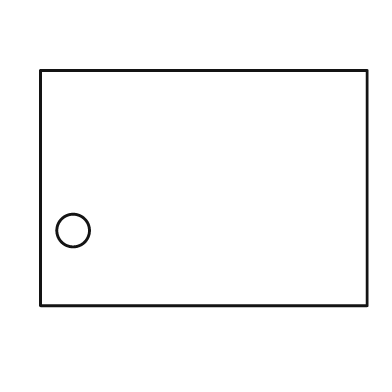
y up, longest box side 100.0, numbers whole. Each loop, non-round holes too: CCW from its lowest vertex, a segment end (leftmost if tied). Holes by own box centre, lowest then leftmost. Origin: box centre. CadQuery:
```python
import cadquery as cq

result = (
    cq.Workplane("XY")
    .moveTo(-50.0, -36.0)
    .lineTo(50.0, -36.0)
    .lineTo(50.0, 36.0)
    .lineTo(-50.0, 36.0)
    .close()
    .moveTo(-40.0, -13.0)
    .circle(5.0)
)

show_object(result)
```